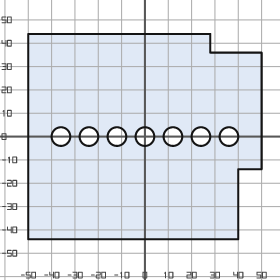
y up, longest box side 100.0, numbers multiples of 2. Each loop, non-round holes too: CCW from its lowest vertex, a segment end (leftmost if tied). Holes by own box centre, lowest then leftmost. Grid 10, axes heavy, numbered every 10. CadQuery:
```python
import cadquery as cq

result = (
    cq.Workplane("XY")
    .moveTo(-50.0, -44.0)
    .lineTo(40.0, -44.0)
    .lineTo(40.0, -14.0)
    .lineTo(50.0, -14.0)
    .lineTo(50.0, 36.0)
    .lineTo(28.0, 36.0)
    .lineTo(28.0, 44.0)
    .lineTo(-50.0, 44.0)
    .close()
    .moveTo(-36.0, 0.0)
    .circle(4.0)
    .moveTo(-24.0, 0.0)
    .circle(4.0)
    .moveTo(-12.0, 0.0)
    .circle(4.0)
    .moveTo(0.0, 0.0)
    .circle(4.0)
    .moveTo(12.0, 0.0)
    .circle(4.0)
    .moveTo(24.0, 0.0)
    .circle(4.0)
    .moveTo(36.0, 0.0)
    .circle(4.0)
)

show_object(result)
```